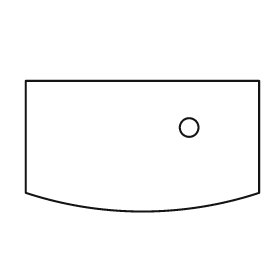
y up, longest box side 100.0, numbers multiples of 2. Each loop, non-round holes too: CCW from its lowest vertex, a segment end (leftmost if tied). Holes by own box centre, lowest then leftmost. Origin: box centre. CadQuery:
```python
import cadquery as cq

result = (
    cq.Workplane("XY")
    .moveTo(-50.0, -20.0)
    .threePointArc((0.0, -28.0), (50.0, -20.0))
    .lineTo(50.0, 28.0)
    .lineTo(-50.0, 28.0)
    .close()
    .moveTo(20.0, 8.0)
    .circle(4.0)
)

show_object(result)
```